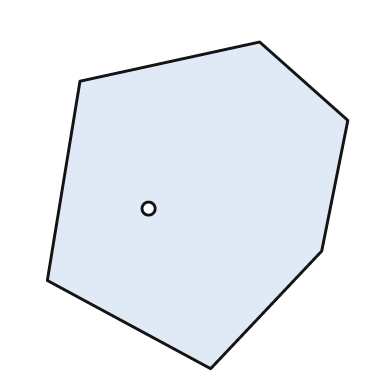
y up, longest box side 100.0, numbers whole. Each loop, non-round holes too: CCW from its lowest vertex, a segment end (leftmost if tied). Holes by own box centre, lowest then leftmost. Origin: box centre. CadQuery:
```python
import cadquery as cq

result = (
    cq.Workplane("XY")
    .moveTo(4.0, -50.0)
    .lineTo(38.0, -14.0)
    .lineTo(46.0, 26.0)
    .lineTo(19.0, 50.0)
    .lineTo(-36.0, 38.0)
    .lineTo(-46.0, -23.0)
    .close()
    .moveTo(-15.0, -1.0)
    .circle(2.0)
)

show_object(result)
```